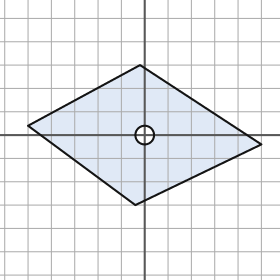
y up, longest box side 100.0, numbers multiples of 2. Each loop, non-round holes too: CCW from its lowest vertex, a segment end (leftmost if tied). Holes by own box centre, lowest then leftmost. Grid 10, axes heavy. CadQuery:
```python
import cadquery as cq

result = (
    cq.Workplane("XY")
    .moveTo(-4.0, -30.0)
    .lineTo(50.0, -4.0)
    .lineTo(-2.0, 30.0)
    .lineTo(-50.0, 4.0)
    .close()
    .moveTo(0.0, 0.0)
    .circle(4.0)
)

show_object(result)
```